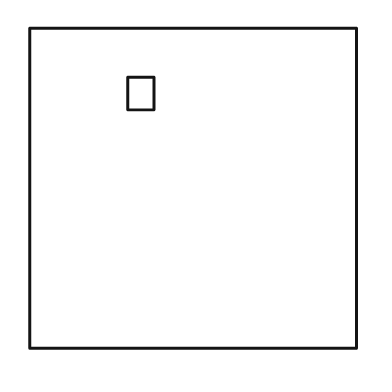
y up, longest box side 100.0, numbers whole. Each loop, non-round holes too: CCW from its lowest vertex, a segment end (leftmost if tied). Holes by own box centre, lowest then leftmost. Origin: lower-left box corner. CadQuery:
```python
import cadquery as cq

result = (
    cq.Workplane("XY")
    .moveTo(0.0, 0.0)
    .lineTo(100.0, 0.0)
    .lineTo(100.0, 98.0)
    .lineTo(0.0, 98.0)
    .close()
    .moveTo(30.0, 73.0)
    .lineTo(38.0, 73.0)
    .lineTo(38.0, 83.0)
    .lineTo(30.0, 83.0)
    .close()
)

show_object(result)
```